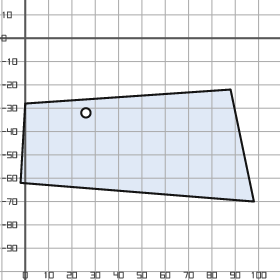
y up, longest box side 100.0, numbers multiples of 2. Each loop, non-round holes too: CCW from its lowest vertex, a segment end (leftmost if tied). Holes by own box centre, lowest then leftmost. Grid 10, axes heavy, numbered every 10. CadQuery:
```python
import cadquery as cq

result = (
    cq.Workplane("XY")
    .moveTo(98.0, -70.0)
    .lineTo(88.0, -22.0)
    .lineTo(0.0, -28.0)
    .lineTo(-2.0, -62.0)
    .close()
    .moveTo(26.0, -32.0)
    .circle(2.0)
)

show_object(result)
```